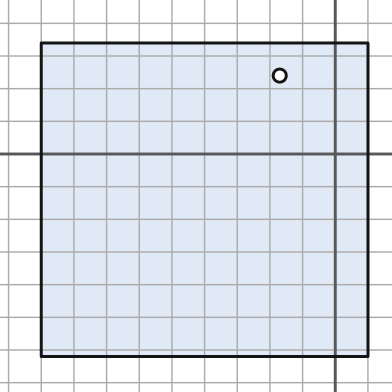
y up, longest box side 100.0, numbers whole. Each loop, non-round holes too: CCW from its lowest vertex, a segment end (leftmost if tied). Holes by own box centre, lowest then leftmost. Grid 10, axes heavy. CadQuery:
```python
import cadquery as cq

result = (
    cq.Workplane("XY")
    .moveTo(-90.0, -62.0)
    .lineTo(10.0, -62.0)
    .lineTo(10.0, 34.0)
    .lineTo(-90.0, 34.0)
    .close()
    .moveTo(-17.0, 24.0)
    .circle(2.0)
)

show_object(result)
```